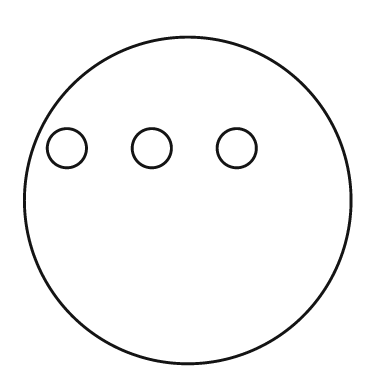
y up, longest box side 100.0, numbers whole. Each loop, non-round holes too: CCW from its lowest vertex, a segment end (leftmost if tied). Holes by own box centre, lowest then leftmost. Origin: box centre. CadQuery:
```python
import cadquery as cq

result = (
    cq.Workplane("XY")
    .moveTo(0.0, 0.0)
    .circle(50.0)
    .moveTo(-37.0, 16.0)
    .circle(6.0)
    .moveTo(-11.0, 16.0)
    .circle(6.0)
    .moveTo(15.0, 16.0)
    .circle(6.0)
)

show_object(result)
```